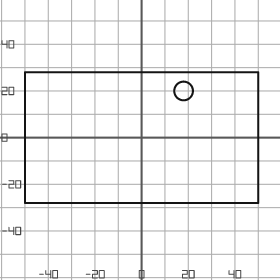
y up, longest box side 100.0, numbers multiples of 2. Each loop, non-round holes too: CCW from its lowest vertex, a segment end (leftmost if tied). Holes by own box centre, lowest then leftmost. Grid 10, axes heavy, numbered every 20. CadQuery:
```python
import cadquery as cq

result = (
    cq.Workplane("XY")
    .moveTo(-50.0, -28.0)
    .lineTo(50.0, -28.0)
    .lineTo(50.0, 28.0)
    .lineTo(-50.0, 28.0)
    .close()
    .moveTo(18.0, 20.0)
    .circle(4.0)
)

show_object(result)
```